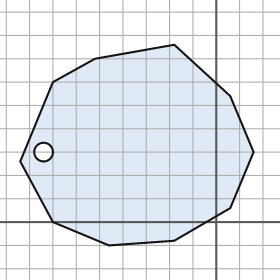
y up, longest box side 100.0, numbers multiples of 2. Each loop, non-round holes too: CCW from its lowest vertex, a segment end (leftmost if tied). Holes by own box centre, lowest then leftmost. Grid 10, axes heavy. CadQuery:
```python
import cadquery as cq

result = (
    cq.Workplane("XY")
    .moveTo(-46.0, -10.0)
    .lineTo(-18.0, -8.0)
    .lineTo(6.0, 6.0)
    .lineTo(16.0, 30.0)
    .lineTo(6.0, 54.0)
    .lineTo(-18.0, 76.0)
    .lineTo(-52.0, 70.0)
    .lineTo(-70.0, 60.0)
    .lineTo(-84.0, 26.0)
    .lineTo(-70.0, 0.0)
    .close()
    .moveTo(-74.0, 30.0)
    .circle(4.0)
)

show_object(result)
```